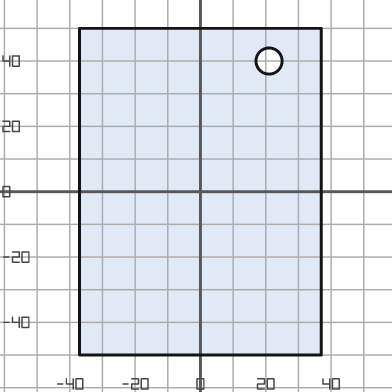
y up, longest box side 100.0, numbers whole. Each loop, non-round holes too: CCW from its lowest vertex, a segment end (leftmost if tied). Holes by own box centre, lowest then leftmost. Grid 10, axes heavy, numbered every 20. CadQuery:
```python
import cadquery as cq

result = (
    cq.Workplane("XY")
    .moveTo(-37.0, -50.0)
    .lineTo(37.0, -50.0)
    .lineTo(37.0, 50.0)
    .lineTo(-37.0, 50.0)
    .close()
    .moveTo(21.0, 40.0)
    .circle(4.0)
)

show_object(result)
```